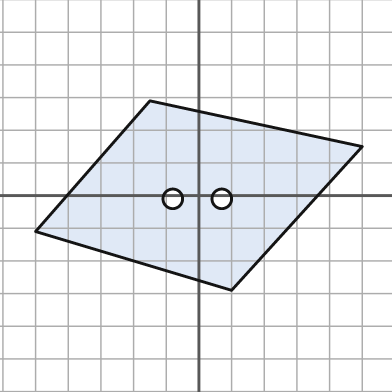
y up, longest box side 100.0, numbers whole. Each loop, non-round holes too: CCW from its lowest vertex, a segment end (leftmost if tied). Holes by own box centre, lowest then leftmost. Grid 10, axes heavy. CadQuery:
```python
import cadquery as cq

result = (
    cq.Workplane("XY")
    .moveTo(10.0, -29.0)
    .lineTo(50.0, 15.0)
    .lineTo(-15.0, 29.0)
    .lineTo(-50.0, -11.0)
    .close()
    .moveTo(-8.0, -1.0)
    .circle(3.0)
    .moveTo(7.0, -1.0)
    .circle(3.0)
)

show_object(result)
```